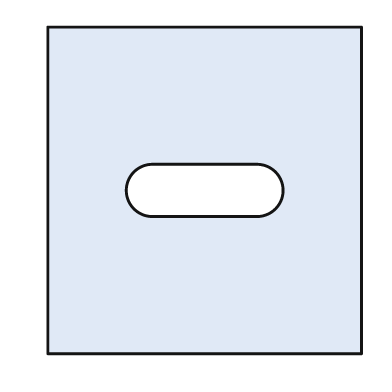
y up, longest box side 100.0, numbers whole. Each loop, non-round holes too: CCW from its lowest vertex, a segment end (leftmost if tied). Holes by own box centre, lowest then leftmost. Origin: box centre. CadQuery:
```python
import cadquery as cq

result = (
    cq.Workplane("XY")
    .moveTo(-48.0, -50.0)
    .lineTo(48.0, -50.0)
    .lineTo(48.0, 50.0)
    .lineTo(-48.0, 50.0)
    .close()
    .moveTo(-16.0, -8.0)
    .lineTo(16.0, -8.0)
    .threePointArc((24.0, 0.0), (16.0, 8.0))
    .lineTo(-16.0, 8.0)
    .threePointArc((-24.0, 0.0), (-16.0, -8.0))
    .close()
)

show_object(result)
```